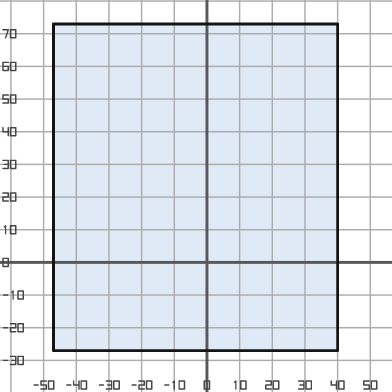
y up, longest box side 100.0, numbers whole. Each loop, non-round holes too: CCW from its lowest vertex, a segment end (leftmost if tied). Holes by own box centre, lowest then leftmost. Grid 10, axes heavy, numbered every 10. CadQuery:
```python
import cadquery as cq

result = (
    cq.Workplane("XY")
    .moveTo(-47.0, -27.0)
    .lineTo(40.0, -27.0)
    .lineTo(40.0, 73.0)
    .lineTo(-47.0, 73.0)
    .close()
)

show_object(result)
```